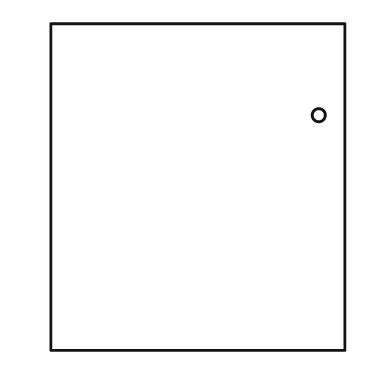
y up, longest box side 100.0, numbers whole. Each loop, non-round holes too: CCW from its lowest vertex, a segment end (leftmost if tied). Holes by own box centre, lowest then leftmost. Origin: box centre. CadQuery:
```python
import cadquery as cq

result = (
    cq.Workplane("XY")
    .moveTo(-45.0, -50.0)
    .lineTo(45.0, -50.0)
    .lineTo(45.0, 50.0)
    .lineTo(-45.0, 50.0)
    .close()
    .moveTo(37.0, 22.0)
    .circle(2.0)
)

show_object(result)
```